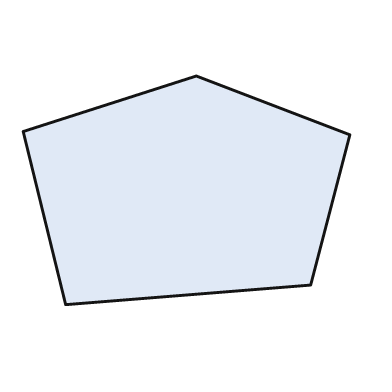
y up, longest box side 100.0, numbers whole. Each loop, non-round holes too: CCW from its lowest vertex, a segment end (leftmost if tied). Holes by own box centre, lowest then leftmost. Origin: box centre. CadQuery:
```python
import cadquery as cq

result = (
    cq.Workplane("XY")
    .moveTo(-37.0, -35.0)
    .lineTo(38.0, -29.0)
    .lineTo(50.0, 17.0)
    .lineTo(3.0, 35.0)
    .lineTo(-50.0, 18.0)
    .close()
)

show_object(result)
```